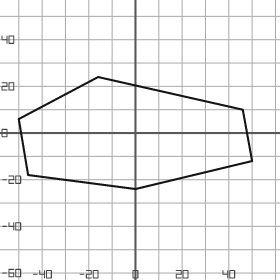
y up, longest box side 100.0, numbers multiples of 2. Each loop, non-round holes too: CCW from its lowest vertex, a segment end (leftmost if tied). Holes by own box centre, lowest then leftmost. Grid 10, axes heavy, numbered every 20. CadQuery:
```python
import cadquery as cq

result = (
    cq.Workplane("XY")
    .moveTo(0.0, -24.0)
    .lineTo(50.0, -12.0)
    .lineTo(46.0, 10.0)
    .lineTo(-16.0, 24.0)
    .lineTo(-50.0, 6.0)
    .lineTo(-46.0, -18.0)
    .close()
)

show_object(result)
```